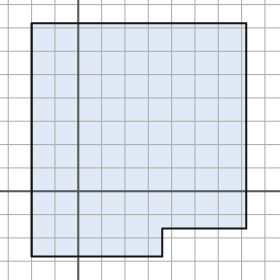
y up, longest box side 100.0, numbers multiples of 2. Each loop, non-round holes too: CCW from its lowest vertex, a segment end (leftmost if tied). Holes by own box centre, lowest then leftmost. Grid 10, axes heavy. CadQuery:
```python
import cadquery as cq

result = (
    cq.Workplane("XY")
    .moveTo(-20.0, -28.0)
    .lineTo(36.0, -28.0)
    .lineTo(36.0, -16.0)
    .lineTo(72.0, -16.0)
    .lineTo(72.0, 72.0)
    .lineTo(-20.0, 72.0)
    .close()
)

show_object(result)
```